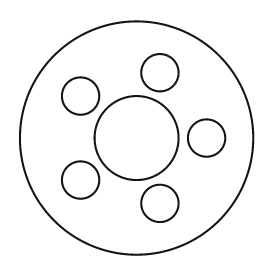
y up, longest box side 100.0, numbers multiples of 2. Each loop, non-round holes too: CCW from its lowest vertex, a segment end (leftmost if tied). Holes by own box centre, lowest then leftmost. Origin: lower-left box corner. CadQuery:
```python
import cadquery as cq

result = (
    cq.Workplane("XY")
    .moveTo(50.0, 50.0)
    .circle(50.0)
    .moveTo(60.0, 22.0)
    .circle(8.0)
    .moveTo(26.0, 32.0)
    .circle(8.0)
    .moveTo(50.0, 50.0)
    .circle(18.0)
    .moveTo(80.0, 50.0)
    .circle(8.0)
    .moveTo(26.0, 68.0)
    .circle(8.0)
    .moveTo(60.0, 78.0)
    .circle(8.0)
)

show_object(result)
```